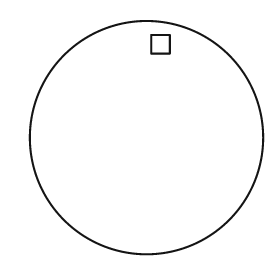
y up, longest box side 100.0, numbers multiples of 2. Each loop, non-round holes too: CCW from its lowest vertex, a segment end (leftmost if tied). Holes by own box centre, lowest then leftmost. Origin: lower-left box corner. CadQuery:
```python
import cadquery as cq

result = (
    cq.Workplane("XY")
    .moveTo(50.0, 50.0)
    .circle(50.0)
    .moveTo(52.0, 86.0)
    .lineTo(60.0, 86.0)
    .lineTo(60.0, 94.0)
    .lineTo(52.0, 94.0)
    .close()
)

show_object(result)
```